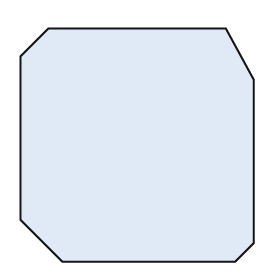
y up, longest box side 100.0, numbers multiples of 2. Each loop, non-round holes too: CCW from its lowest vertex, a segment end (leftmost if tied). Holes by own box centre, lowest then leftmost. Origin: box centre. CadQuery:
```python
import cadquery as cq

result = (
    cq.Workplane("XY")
    .moveTo(-32.0, -50.0)
    .lineTo(42.0, -50.0)
    .lineTo(50.0, -42.0)
    .lineTo(50.0, 28.0)
    .lineTo(38.0, 50.0)
    .lineTo(-38.0, 50.0)
    .lineTo(-50.0, 38.0)
    .lineTo(-50.0, -32.0)
    .close()
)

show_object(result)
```